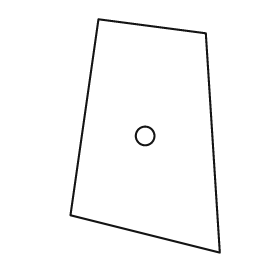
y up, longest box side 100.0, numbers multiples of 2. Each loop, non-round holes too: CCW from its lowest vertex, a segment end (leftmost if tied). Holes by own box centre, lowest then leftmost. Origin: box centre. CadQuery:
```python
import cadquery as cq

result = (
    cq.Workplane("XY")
    .moveTo(32.0, -50.0)
    .lineTo(26.0, 44.0)
    .lineTo(-20.0, 50.0)
    .lineTo(-32.0, -34.0)
    .close()
    .moveTo(0.0, 0.0)
    .circle(4.0)
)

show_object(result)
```